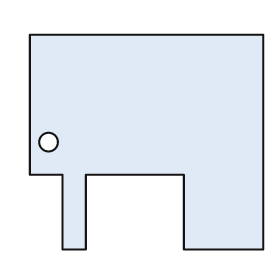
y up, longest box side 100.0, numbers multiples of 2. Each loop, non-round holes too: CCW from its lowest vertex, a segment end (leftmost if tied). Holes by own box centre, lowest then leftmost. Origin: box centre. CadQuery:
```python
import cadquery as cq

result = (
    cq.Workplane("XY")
    .moveTo(-36.0, -46.0)
    .lineTo(-26.0, -46.0)
    .lineTo(-26.0, -14.0)
    .lineTo(16.0, -14.0)
    .lineTo(16.0, -46.0)
    .lineTo(50.0, -46.0)
    .lineTo(50.0, 46.0)
    .lineTo(-50.0, 46.0)
    .lineTo(-50.0, -14.0)
    .lineTo(-36.0, -14.0)
    .close()
    .moveTo(-42.0, 0.0)
    .circle(4.0)
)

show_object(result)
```